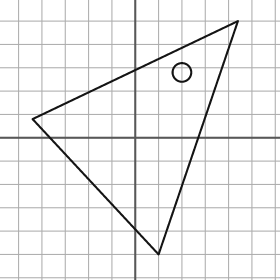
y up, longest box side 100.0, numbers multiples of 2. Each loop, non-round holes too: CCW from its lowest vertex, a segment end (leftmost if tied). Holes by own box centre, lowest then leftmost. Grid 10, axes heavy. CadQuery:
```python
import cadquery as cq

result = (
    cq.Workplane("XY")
    .moveTo(10.0, -50.0)
    .lineTo(44.0, 50.0)
    .lineTo(-44.0, 8.0)
    .close()
    .moveTo(20.0, 28.0)
    .circle(4.0)
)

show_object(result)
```